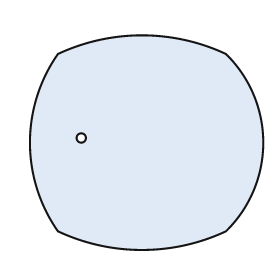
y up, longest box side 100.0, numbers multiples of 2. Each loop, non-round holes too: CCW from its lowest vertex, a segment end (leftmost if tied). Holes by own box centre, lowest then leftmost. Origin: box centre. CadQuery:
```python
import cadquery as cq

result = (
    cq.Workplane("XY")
    .moveTo(-38.0, -38.0)
    .threePointArc((-2.0, -46.0), (34.0, -38.0))
    .threePointArc((50.0, 0.0), (34.0, 38.0))
    .threePointArc((-2.0, 46.0), (-38.0, 38.0))
    .threePointArc((-50.0, 0.0), (-38.0, -38.0))
    .close()
    .moveTo(-28.0, 2.0)
    .circle(2.0)
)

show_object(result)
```